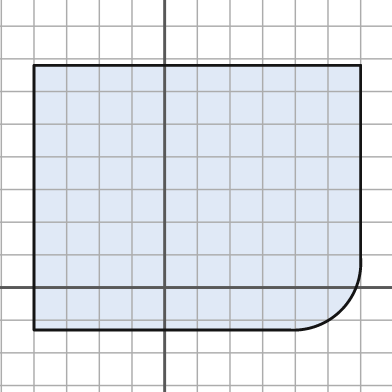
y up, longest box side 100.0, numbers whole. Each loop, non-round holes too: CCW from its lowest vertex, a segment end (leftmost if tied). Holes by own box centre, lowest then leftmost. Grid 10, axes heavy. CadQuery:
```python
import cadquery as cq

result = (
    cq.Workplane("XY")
    .moveTo(-40.0, -13.0)
    .lineTo(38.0, -13.0)
    .threePointArc((54.0, -7.0), (60.0, 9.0))
    .lineTo(60.0, 68.0)
    .lineTo(-40.0, 68.0)
    .close()
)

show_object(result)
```